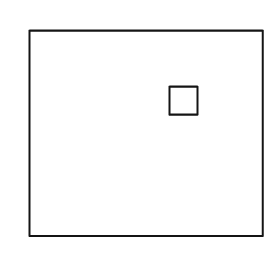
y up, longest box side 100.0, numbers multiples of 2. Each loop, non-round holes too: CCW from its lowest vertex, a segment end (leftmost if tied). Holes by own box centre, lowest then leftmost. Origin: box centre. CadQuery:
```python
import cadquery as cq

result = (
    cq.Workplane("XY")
    .moveTo(-50.0, -44.0)
    .lineTo(50.0, -44.0)
    .lineTo(50.0, 44.0)
    .lineTo(-50.0, 44.0)
    .close()
    .moveTo(10.0, 8.0)
    .lineTo(22.0, 8.0)
    .lineTo(22.0, 20.0)
    .lineTo(10.0, 20.0)
    .close()
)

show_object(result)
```